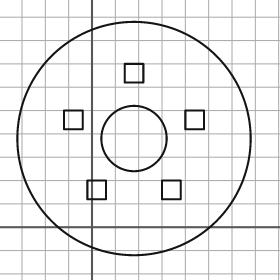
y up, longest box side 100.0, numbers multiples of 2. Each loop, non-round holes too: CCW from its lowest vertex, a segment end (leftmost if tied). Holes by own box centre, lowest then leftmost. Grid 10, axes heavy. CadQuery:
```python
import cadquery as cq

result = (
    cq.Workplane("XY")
    .moveTo(18.0, 38.0)
    .circle(50.0)
    .moveTo(-2.0, 12.0)
    .lineTo(6.0, 12.0)
    .lineTo(6.0, 20.0)
    .lineTo(-2.0, 20.0)
    .close()
    .moveTo(30.0, 12.0)
    .lineTo(38.0, 12.0)
    .lineTo(38.0, 20.0)
    .lineTo(30.0, 20.0)
    .close()
    .moveTo(18.0, 38.0)
    .circle(14.0)
    .moveTo(-12.0, 42.0)
    .lineTo(-4.0, 42.0)
    .lineTo(-4.0, 50.0)
    .lineTo(-12.0, 50.0)
    .close()
    .moveTo(40.0, 42.0)
    .lineTo(48.0, 42.0)
    .lineTo(48.0, 50.0)
    .lineTo(40.0, 50.0)
    .close()
    .moveTo(14.0, 62.0)
    .lineTo(22.0, 62.0)
    .lineTo(22.0, 70.0)
    .lineTo(14.0, 70.0)
    .close()
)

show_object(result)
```